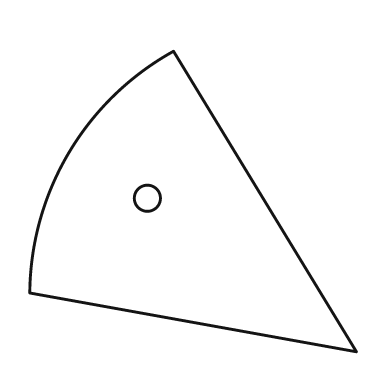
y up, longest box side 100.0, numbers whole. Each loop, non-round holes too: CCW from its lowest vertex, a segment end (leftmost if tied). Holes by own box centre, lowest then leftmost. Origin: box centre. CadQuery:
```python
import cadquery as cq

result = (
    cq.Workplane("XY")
    .moveTo(50.0, -46.0)
    .lineTo(-6.0, 46.0)
    .threePointArc((-38.0, 15.0), (-50.0, -28.0))
    .close()
    .moveTo(-14.0, 1.0)
    .circle(4.0)
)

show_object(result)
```